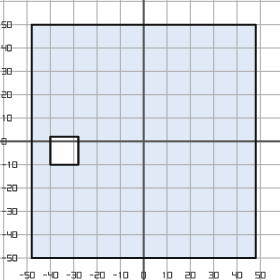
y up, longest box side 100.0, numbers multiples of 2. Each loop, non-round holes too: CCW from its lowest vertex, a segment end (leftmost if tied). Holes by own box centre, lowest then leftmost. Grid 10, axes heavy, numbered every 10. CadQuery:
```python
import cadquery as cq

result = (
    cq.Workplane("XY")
    .moveTo(-48.0, -50.0)
    .lineTo(48.0, -50.0)
    .lineTo(48.0, 50.0)
    .lineTo(-48.0, 50.0)
    .close()
    .moveTo(-40.0, -10.0)
    .lineTo(-28.0, -10.0)
    .lineTo(-28.0, 2.0)
    .lineTo(-40.0, 2.0)
    .close()
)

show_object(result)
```